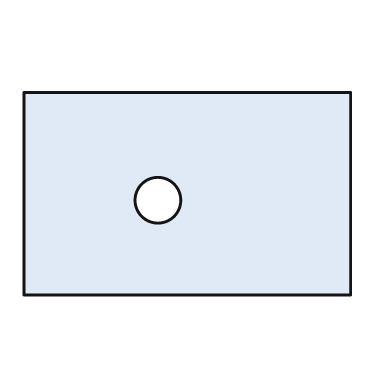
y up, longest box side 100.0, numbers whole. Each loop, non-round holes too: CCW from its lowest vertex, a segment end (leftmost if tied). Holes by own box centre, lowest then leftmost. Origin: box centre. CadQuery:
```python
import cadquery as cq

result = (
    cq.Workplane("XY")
    .moveTo(-50.0, -31.0)
    .lineTo(50.0, -31.0)
    .lineTo(50.0, 31.0)
    .lineTo(-50.0, 31.0)
    .close()
    .moveTo(-9.0, -2.0)
    .circle(7.0)
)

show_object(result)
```